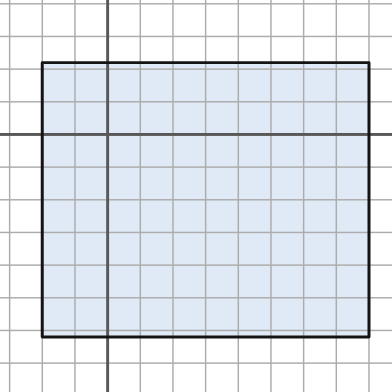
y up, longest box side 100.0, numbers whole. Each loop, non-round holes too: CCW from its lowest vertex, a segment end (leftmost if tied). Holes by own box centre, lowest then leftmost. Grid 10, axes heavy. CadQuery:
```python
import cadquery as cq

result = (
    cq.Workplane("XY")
    .moveTo(-20.0, -62.0)
    .lineTo(80.0, -62.0)
    .lineTo(80.0, 22.0)
    .lineTo(-20.0, 22.0)
    .close()
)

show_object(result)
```